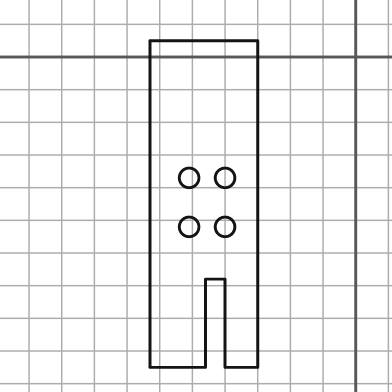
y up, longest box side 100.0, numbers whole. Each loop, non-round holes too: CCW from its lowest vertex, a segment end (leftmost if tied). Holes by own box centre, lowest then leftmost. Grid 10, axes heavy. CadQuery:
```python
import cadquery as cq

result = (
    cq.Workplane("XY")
    .moveTo(-63.0, -95.0)
    .lineTo(-46.0, -95.0)
    .lineTo(-46.0, -68.0)
    .lineTo(-40.0, -68.0)
    .lineTo(-40.0, -95.0)
    .lineTo(-30.0, -95.0)
    .lineTo(-30.0, 5.0)
    .lineTo(-63.0, 5.0)
    .close()
    .moveTo(-51.0, -52.0)
    .circle(3.0)
    .moveTo(-40.0, -52.0)
    .circle(3.0)
    .moveTo(-51.0, -37.0)
    .circle(3.0)
    .moveTo(-40.0, -37.0)
    .circle(3.0)
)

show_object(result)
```